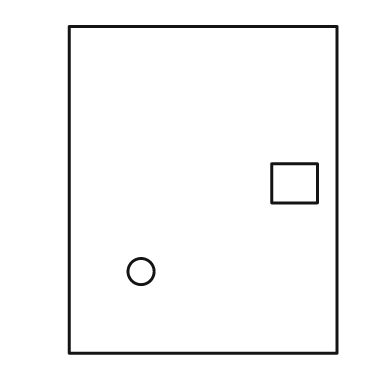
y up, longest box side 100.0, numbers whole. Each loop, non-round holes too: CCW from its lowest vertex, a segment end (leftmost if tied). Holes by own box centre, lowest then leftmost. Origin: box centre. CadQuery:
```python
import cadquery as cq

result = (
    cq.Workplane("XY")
    .moveTo(-41.0, -50.0)
    .lineTo(41.0, -50.0)
    .lineTo(41.0, 50.0)
    .lineTo(-41.0, 50.0)
    .close()
    .moveTo(-19.0, -25.0)
    .circle(4.0)
    .moveTo(21.0, -4.0)
    .lineTo(35.0, -4.0)
    .lineTo(35.0, 8.0)
    .lineTo(21.0, 8.0)
    .close()
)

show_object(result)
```